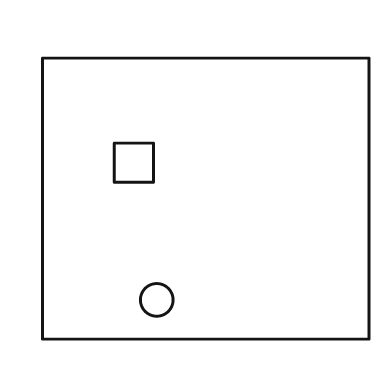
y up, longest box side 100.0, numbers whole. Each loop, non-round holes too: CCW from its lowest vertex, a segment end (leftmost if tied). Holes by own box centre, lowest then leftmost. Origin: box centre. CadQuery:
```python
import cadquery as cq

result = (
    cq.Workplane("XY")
    .moveTo(-50.0, -43.0)
    .lineTo(50.0, -43.0)
    .lineTo(50.0, 43.0)
    .lineTo(-50.0, 43.0)
    .close()
    .moveTo(-15.0, -31.0)
    .circle(5.0)
    .moveTo(-28.0, 5.0)
    .lineTo(-16.0, 5.0)
    .lineTo(-16.0, 17.0)
    .lineTo(-28.0, 17.0)
    .close()
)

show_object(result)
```